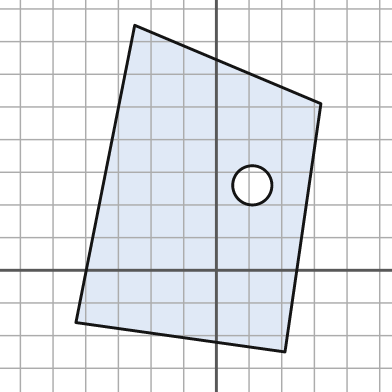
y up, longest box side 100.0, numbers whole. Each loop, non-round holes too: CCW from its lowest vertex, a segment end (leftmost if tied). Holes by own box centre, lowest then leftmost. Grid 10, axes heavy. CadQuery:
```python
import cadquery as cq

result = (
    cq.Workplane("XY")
    .moveTo(21.0, -25.0)
    .lineTo(32.0, 51.0)
    .lineTo(-25.0, 75.0)
    .lineTo(-43.0, -16.0)
    .close()
    .moveTo(11.0, 26.0)
    .circle(6.0)
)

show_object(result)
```